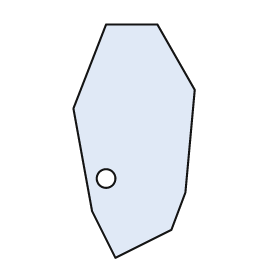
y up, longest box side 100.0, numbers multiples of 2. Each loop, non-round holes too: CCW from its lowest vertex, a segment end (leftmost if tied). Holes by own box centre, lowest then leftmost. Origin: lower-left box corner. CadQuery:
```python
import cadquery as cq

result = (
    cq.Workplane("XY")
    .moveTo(18.0, 0.0)
    .lineTo(42.0, 12.0)
    .lineTo(48.0, 28.0)
    .lineTo(52.0, 72.0)
    .lineTo(36.0, 100.0)
    .lineTo(14.0, 100.0)
    .lineTo(0.0, 64.0)
    .lineTo(8.0, 20.0)
    .close()
    .moveTo(14.0, 34.0)
    .circle(4.0)
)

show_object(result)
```